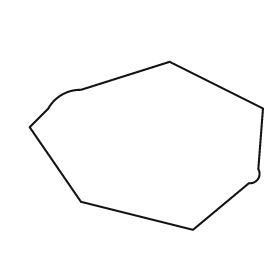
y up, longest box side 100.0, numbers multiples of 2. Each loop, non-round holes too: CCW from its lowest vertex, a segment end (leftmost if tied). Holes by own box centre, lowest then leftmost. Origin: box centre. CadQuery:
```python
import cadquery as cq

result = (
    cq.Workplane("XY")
    .moveTo(20.0, -36.0)
    .lineTo(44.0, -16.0)
    .threePointArc((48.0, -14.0), (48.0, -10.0))
    .lineTo(50.0, 16.0)
    .lineTo(10.0, 36.0)
    .lineTo(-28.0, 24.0)
    .threePointArc((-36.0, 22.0), (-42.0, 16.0))
    .lineTo(-50.0, 8.0)
    .lineTo(-28.0, -24.0)
    .close()
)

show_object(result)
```